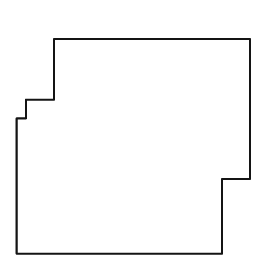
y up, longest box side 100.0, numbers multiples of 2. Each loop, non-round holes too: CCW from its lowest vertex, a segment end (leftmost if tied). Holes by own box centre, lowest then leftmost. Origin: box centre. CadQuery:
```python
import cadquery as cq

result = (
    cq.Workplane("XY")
    .moveTo(-50.0, -46.0)
    .lineTo(38.0, -46.0)
    .lineTo(38.0, -14.0)
    .lineTo(50.0, -14.0)
    .lineTo(50.0, 46.0)
    .lineTo(-34.0, 46.0)
    .lineTo(-34.0, 20.0)
    .lineTo(-46.0, 20.0)
    .lineTo(-46.0, 12.0)
    .lineTo(-50.0, 12.0)
    .close()
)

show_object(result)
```